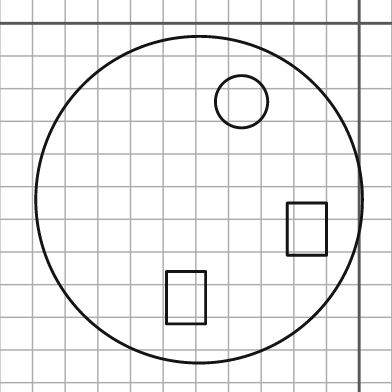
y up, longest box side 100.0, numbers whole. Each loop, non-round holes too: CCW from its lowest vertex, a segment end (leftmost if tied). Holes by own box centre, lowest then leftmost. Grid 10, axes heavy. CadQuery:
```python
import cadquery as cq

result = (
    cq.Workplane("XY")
    .moveTo(-49.0, -54.0)
    .circle(50.0)
    .moveTo(-59.0, -92.0)
    .lineTo(-47.0, -92.0)
    .lineTo(-47.0, -76.0)
    .lineTo(-59.0, -76.0)
    .close()
    .moveTo(-22.0, -71.0)
    .lineTo(-10.0, -71.0)
    .lineTo(-10.0, -55.0)
    .lineTo(-22.0, -55.0)
    .close()
    .moveTo(-36.0, -24.0)
    .circle(8.0)
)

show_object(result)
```